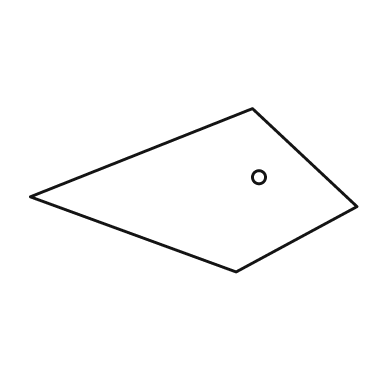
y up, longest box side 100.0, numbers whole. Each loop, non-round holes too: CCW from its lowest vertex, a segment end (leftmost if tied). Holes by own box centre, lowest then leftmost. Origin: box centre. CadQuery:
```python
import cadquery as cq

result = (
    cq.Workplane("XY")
    .moveTo(13.0, -25.0)
    .lineTo(50.0, -5.0)
    .lineTo(18.0, 25.0)
    .lineTo(-50.0, -2.0)
    .close()
    .moveTo(20.0, 4.0)
    .circle(2.0)
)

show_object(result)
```